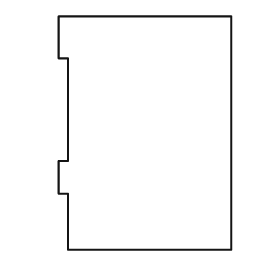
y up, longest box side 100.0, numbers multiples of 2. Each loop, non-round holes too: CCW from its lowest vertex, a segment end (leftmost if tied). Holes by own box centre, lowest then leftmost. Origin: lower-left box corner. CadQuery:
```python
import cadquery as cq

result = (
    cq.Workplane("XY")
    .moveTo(4.0, 0.0)
    .lineTo(74.0, 0.0)
    .lineTo(74.0, 100.0)
    .lineTo(0.0, 100.0)
    .lineTo(0.0, 82.0)
    .lineTo(4.0, 82.0)
    .lineTo(4.0, 38.0)
    .lineTo(0.0, 38.0)
    .lineTo(0.0, 24.0)
    .lineTo(4.0, 24.0)
    .close()
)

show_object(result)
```